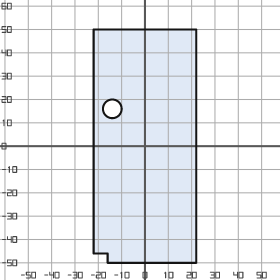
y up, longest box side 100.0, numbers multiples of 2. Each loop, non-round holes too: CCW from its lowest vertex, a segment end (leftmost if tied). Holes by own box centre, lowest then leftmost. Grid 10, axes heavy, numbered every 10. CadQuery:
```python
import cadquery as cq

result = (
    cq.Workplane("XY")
    .moveTo(-16.0, -50.0)
    .lineTo(22.0, -50.0)
    .lineTo(22.0, 50.0)
    .lineTo(-22.0, 50.0)
    .lineTo(-22.0, -46.0)
    .lineTo(-16.0, -46.0)
    .close()
    .moveTo(-14.0, 16.0)
    .circle(4.0)
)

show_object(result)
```